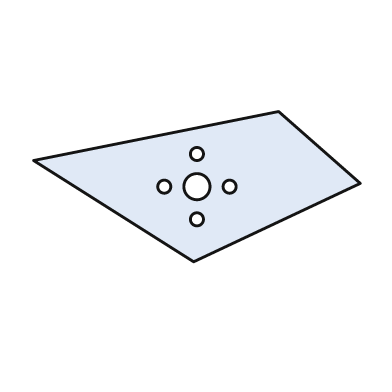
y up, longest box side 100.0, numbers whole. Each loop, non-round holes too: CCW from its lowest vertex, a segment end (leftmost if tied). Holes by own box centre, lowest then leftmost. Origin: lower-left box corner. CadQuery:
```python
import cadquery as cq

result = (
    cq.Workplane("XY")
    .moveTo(49.0, 0.0)
    .lineTo(100.0, 24.0)
    .lineTo(75.0, 46.0)
    .lineTo(0.0, 31.0)
    .close()
    .moveTo(50.0, 13.0)
    .circle(2.0)
    .moveTo(40.0, 23.0)
    .circle(2.0)
    .moveTo(50.0, 23.0)
    .circle(4.0)
    .moveTo(60.0, 23.0)
    .circle(2.0)
    .moveTo(50.0, 33.0)
    .circle(2.0)
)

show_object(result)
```